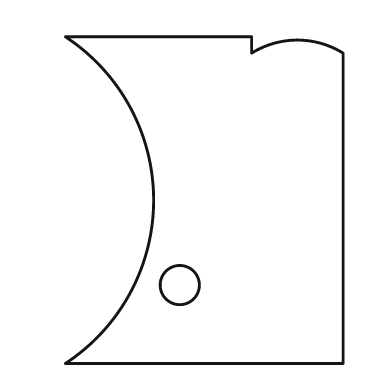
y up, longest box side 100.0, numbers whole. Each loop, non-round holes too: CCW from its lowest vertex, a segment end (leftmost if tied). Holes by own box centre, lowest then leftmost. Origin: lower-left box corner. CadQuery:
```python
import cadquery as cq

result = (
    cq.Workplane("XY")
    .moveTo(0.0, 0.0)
    .lineTo(85.0, 0.0)
    .lineTo(85.0, 95.0)
    .threePointArc((71.0, 99.0), (57.0, 95.0))
    .lineTo(57.0, 100.0)
    .lineTo(0.0, 100.0)
    .threePointArc((27.0, 50.0), (0.0, 0.0))
    .close()
    .moveTo(35.0, 24.0)
    .circle(6.0)
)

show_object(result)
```